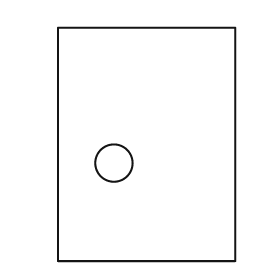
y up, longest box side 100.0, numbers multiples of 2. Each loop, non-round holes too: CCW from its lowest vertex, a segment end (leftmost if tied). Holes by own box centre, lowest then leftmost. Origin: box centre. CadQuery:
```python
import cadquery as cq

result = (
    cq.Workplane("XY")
    .moveTo(-38.0, -50.0)
    .lineTo(38.0, -50.0)
    .lineTo(38.0, 50.0)
    .lineTo(-38.0, 50.0)
    .close()
    .moveTo(-14.0, -8.0)
    .circle(8.0)
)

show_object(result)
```